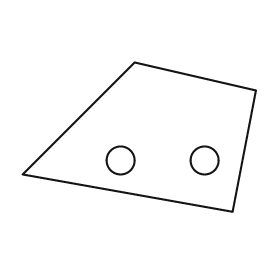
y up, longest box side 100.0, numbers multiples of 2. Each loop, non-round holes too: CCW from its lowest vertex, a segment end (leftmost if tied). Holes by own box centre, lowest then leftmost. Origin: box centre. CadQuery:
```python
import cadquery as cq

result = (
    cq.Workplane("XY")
    .moveTo(40.0, -32.0)
    .lineTo(50.0, 20.0)
    .lineTo(-2.0, 32.0)
    .lineTo(-50.0, -16.0)
    .close()
    .moveTo(-8.0, -10.0)
    .circle(6.0)
    .moveTo(28.0, -10.0)
    .circle(6.0)
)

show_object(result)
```